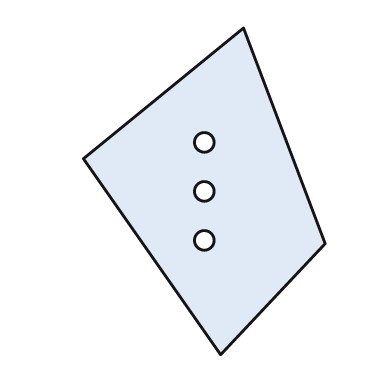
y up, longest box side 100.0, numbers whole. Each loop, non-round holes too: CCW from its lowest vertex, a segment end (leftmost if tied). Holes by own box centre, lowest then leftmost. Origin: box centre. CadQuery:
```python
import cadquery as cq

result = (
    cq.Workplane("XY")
    .moveTo(5.0, -50.0)
    .lineTo(37.0, -16.0)
    .lineTo(12.0, 50.0)
    .lineTo(-37.0, 10.0)
    .close()
    .moveTo(0.0, -15.0)
    .circle(3.0)
    .moveTo(0.0, 0.0)
    .circle(3.0)
    .moveTo(0.0, 15.0)
    .circle(3.0)
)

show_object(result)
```